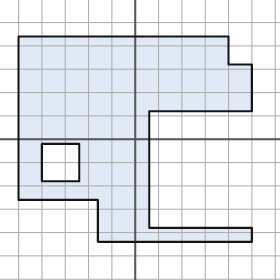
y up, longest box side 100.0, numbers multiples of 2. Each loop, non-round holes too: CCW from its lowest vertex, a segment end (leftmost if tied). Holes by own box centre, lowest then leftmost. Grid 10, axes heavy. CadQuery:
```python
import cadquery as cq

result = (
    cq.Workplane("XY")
    .moveTo(-16.0, -44.0)
    .lineTo(50.0, -44.0)
    .lineTo(50.0, -38.0)
    .lineTo(6.0, -38.0)
    .lineTo(6.0, 12.0)
    .lineTo(50.0, 12.0)
    .lineTo(50.0, 32.0)
    .lineTo(40.0, 32.0)
    .lineTo(40.0, 44.0)
    .lineTo(-50.0, 44.0)
    .lineTo(-50.0, -26.0)
    .lineTo(-16.0, -26.0)
    .close()
    .moveTo(-40.0, -18.0)
    .lineTo(-24.0, -18.0)
    .lineTo(-24.0, -2.0)
    .lineTo(-40.0, -2.0)
    .close()
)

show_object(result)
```